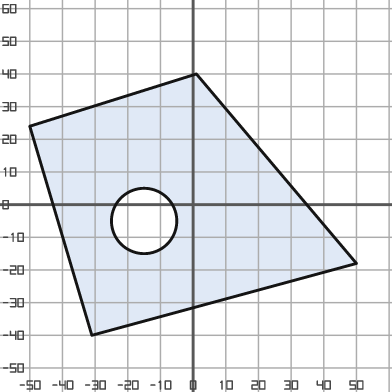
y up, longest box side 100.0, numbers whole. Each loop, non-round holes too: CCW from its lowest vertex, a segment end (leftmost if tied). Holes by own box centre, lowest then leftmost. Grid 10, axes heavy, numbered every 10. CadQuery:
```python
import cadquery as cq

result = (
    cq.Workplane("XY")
    .moveTo(-31.0, -40.0)
    .lineTo(50.0, -18.0)
    .lineTo(1.0, 40.0)
    .lineTo(-50.0, 24.0)
    .close()
    .moveTo(-15.0, -5.0)
    .circle(10.0)
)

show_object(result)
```